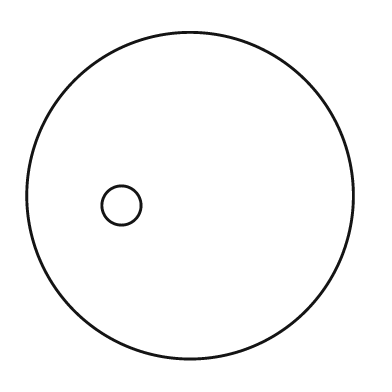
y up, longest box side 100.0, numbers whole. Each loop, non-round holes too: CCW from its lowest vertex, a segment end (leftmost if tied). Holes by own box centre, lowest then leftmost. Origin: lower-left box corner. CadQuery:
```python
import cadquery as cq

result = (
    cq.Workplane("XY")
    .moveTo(50.0, 50.0)
    .circle(50.0)
    .moveTo(29.0, 47.0)
    .circle(6.0)
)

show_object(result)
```